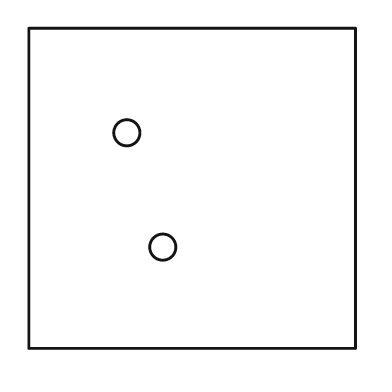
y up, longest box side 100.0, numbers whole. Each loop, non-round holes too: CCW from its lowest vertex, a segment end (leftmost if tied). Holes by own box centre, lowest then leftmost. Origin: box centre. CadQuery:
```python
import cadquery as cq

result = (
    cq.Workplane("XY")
    .moveTo(-50.0, -49.0)
    .lineTo(50.0, -49.0)
    .lineTo(50.0, 49.0)
    .lineTo(-50.0, 49.0)
    .close()
    .moveTo(-9.0, -18.0)
    .circle(4.0)
    .moveTo(-20.0, 17.0)
    .circle(4.0)
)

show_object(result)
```